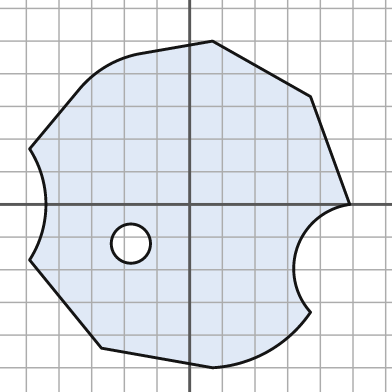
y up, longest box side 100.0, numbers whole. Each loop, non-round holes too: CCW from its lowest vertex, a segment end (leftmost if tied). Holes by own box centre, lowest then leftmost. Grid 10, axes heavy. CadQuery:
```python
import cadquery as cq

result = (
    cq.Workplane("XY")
    .moveTo(7.0, -50.0)
    .threePointArc((24.0, -45.0), (37.0, -33.0))
    .threePointArc((33.0, -13.0), (49.0, 0.0))
    .lineTo(37.0, 33.0)
    .lineTo(7.0, 50.0)
    .lineTo(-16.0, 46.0)
    .threePointArc((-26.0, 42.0), (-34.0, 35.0))
    .lineTo(-49.0, 17.0)
    .threePointArc((-44.0, 0.0), (-49.0, -17.0))
    .lineTo(-27.0, -44.0)
    .close()
    .moveTo(-18.0, -12.0)
    .circle(6.0)
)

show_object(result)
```